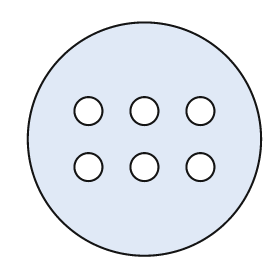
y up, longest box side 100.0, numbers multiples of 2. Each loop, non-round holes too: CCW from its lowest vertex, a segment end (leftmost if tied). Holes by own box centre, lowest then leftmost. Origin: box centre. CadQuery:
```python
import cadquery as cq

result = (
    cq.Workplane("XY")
    .moveTo(0.0, 0.0)
    .circle(50.0)
    .moveTo(-24.0, -12.0)
    .circle(6.0)
    .moveTo(0.0, -12.0)
    .circle(6.0)
    .moveTo(24.0, -12.0)
    .circle(6.0)
    .moveTo(-24.0, 12.0)
    .circle(6.0)
    .moveTo(0.0, 12.0)
    .circle(6.0)
    .moveTo(24.0, 12.0)
    .circle(6.0)
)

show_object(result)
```